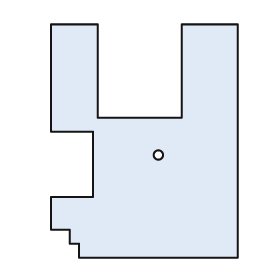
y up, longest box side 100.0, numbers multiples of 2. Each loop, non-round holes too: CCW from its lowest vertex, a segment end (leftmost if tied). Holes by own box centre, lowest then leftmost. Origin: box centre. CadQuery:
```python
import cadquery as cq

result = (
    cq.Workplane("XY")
    .moveTo(-28.0, -50.0)
    .lineTo(40.0, -50.0)
    .lineTo(40.0, 50.0)
    .lineTo(16.0, 50.0)
    .lineTo(16.0, 10.0)
    .lineTo(-20.0, 10.0)
    .lineTo(-20.0, 50.0)
    .lineTo(-40.0, 50.0)
    .lineTo(-40.0, 4.0)
    .lineTo(-22.0, 4.0)
    .lineTo(-22.0, -24.0)
    .lineTo(-40.0, -24.0)
    .lineTo(-40.0, -38.0)
    .lineTo(-32.0, -38.0)
    .lineTo(-32.0, -44.0)
    .lineTo(-28.0, -44.0)
    .close()
    .moveTo(6.0, -6.0)
    .circle(2.0)
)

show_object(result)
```